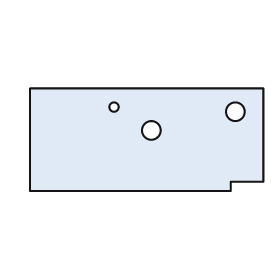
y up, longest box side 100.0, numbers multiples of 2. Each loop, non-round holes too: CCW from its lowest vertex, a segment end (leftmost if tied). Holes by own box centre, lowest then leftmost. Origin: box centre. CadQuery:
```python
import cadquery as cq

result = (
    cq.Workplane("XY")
    .moveTo(-50.0, -22.0)
    .lineTo(36.0, -22.0)
    .lineTo(36.0, -18.0)
    .lineTo(50.0, -18.0)
    .lineTo(50.0, 22.0)
    .lineTo(-50.0, 22.0)
    .close()
    .moveTo(2.0, 4.0)
    .circle(4.0)
    .moveTo(38.0, 12.0)
    .circle(4.0)
    .moveTo(-14.0, 14.0)
    .circle(2.0)
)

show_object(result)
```